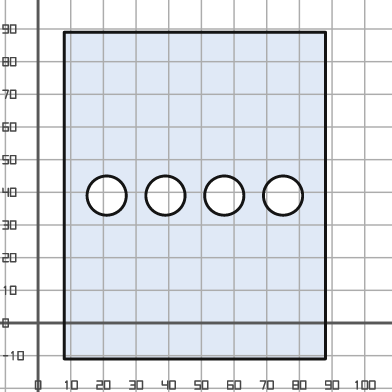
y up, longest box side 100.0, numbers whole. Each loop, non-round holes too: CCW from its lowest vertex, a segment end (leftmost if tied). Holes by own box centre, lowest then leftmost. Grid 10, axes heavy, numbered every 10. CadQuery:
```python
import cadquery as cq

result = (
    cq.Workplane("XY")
    .moveTo(8.0, -11.0)
    .lineTo(88.0, -11.0)
    .lineTo(88.0, 89.0)
    .lineTo(8.0, 89.0)
    .close()
    .moveTo(21.0, 39.0)
    .circle(6.0)
    .moveTo(39.0, 39.0)
    .circle(6.0)
    .moveTo(57.0, 39.0)
    .circle(6.0)
    .moveTo(75.0, 39.0)
    .circle(6.0)
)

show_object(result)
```